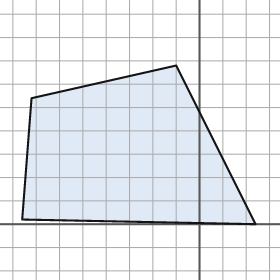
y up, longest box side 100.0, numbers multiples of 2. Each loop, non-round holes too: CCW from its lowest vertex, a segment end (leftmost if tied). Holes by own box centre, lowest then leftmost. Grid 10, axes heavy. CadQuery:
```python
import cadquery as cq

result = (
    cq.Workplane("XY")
    .moveTo(24.0, 0.0)
    .lineTo(-10.0, 68.0)
    .lineTo(-72.0, 54.0)
    .lineTo(-76.0, 2.0)
    .close()
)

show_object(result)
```